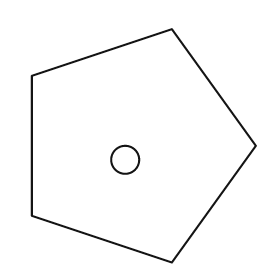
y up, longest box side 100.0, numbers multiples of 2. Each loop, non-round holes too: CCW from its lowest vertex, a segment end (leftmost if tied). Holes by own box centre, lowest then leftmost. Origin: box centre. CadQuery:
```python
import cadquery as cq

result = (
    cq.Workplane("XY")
    .moveTo(12.0, -50.0)
    .lineTo(48.0, 0.0)
    .lineTo(12.0, 50.0)
    .lineTo(-48.0, 30.0)
    .lineTo(-48.0, -30.0)
    .close()
    .moveTo(-8.0, -6.0)
    .circle(6.0)
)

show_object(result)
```